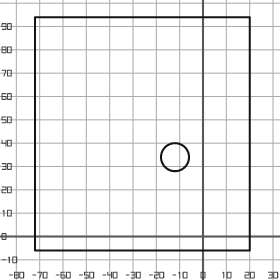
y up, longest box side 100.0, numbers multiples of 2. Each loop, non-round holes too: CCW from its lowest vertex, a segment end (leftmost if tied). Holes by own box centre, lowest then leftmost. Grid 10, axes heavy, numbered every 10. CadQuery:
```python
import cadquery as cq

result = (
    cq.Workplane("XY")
    .moveTo(-72.0, -6.0)
    .lineTo(20.0, -6.0)
    .lineTo(20.0, 94.0)
    .lineTo(-72.0, 94.0)
    .close()
    .moveTo(-12.0, 34.0)
    .circle(6.0)
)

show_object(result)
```